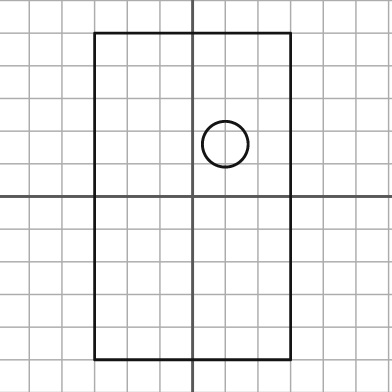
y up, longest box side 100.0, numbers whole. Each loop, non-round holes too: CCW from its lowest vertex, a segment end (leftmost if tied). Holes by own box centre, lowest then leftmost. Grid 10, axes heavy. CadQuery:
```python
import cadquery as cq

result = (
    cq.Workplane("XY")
    .moveTo(-30.0, -50.0)
    .lineTo(30.0, -50.0)
    .lineTo(30.0, 50.0)
    .lineTo(-30.0, 50.0)
    .close()
    .moveTo(10.0, 16.0)
    .circle(7.0)
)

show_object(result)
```